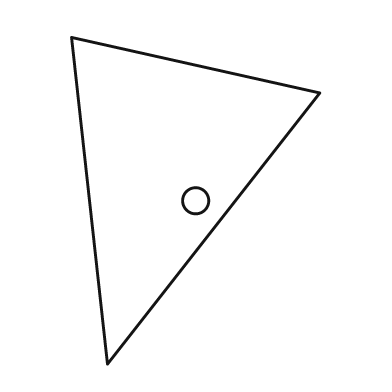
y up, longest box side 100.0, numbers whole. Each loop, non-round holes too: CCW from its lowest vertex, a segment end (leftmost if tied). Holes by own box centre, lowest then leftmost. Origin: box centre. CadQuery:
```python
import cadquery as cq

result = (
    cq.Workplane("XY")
    .moveTo(-27.0, -50.0)
    .lineTo(38.0, 33.0)
    .lineTo(-38.0, 50.0)
    .close()
    .moveTo(0.0, 0.0)
    .circle(4.0)
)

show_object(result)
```